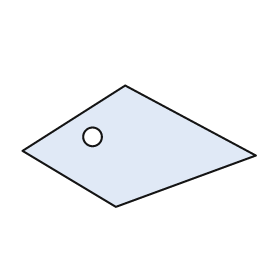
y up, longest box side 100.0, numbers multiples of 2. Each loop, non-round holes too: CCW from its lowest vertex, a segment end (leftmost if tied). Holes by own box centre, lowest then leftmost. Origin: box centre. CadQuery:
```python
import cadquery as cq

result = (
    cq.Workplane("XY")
    .moveTo(-10.0, -26.0)
    .lineTo(50.0, -4.0)
    .lineTo(-6.0, 26.0)
    .lineTo(-50.0, -2.0)
    .close()
    .moveTo(-20.0, 4.0)
    .circle(4.0)
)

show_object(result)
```